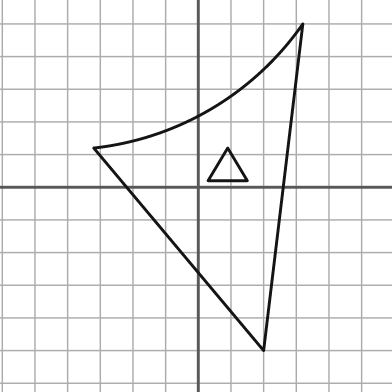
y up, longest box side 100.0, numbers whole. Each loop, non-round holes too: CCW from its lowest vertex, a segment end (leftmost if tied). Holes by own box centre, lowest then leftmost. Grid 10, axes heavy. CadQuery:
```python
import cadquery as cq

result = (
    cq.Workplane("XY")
    .moveTo(20.0, -50.0)
    .lineTo(32.0, 50.0)
    .threePointArc((4.0, 24.0), (-32.0, 12.0))
    .close()
    .moveTo(3.0, 2.0)
    .lineTo(15.0, 2.0)
    .lineTo(9.0, 12.0)
    .close()
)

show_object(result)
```